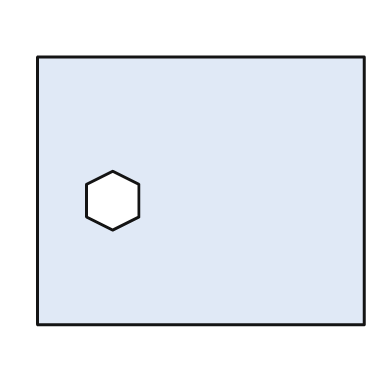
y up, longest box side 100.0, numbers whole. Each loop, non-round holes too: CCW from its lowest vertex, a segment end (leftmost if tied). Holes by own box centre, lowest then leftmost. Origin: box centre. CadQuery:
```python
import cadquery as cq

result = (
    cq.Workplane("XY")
    .moveTo(-50.0, -41.0)
    .lineTo(50.0, -41.0)
    .lineTo(50.0, 41.0)
    .lineTo(-50.0, 41.0)
    .close()
    .moveTo(-27.0, -12.0)
    .lineTo(-19.0, -8.0)
    .lineTo(-19.0, 2.0)
    .lineTo(-27.0, 6.0)
    .lineTo(-35.0, 2.0)
    .lineTo(-35.0, -8.0)
    .close()
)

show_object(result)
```